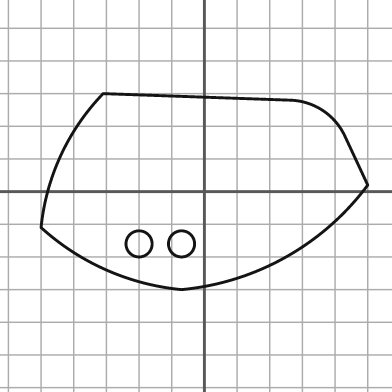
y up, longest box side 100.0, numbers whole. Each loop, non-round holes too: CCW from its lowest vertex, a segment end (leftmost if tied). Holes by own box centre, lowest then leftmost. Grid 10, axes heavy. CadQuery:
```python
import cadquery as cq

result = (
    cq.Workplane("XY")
    .moveTo(-7.0, -30.0)
    .threePointArc((25.0, -20.0), (50.0, 2.0))
    .lineTo(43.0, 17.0)
    .threePointArc((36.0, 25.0), (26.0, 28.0))
    .lineTo(-31.0, 30.0)
    .threePointArc((-44.0, 11.0), (-50.0, -11.0))
    .threePointArc((-30.0, -24.0), (-7.0, -30.0))
    .close()
    .moveTo(-20.0, -16.0)
    .circle(4.0)
    .moveTo(-7.0, -16.0)
    .circle(4.0)
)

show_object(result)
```